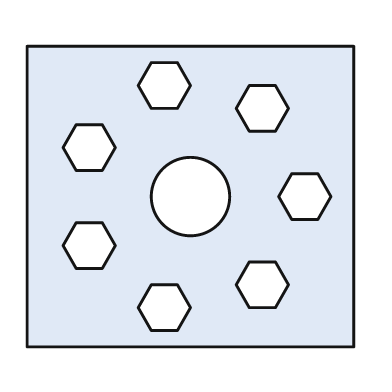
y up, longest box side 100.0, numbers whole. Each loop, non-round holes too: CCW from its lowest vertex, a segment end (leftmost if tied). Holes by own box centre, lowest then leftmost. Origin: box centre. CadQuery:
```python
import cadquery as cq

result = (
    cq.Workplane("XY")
    .moveTo(-50.0, -46.0)
    .lineTo(50.0, -46.0)
    .lineTo(50.0, 46.0)
    .lineTo(-50.0, 46.0)
    .close()
    .moveTo(-12.0, -41.0)
    .lineTo(-4.0, -41.0)
    .lineTo(0.0, -34.0)
    .lineTo(-4.0, -27.0)
    .lineTo(-12.0, -27.0)
    .lineTo(-16.0, -34.0)
    .close()
    .moveTo(18.0, -34.0)
    .lineTo(26.0, -34.0)
    .lineTo(30.0, -27.0)
    .lineTo(26.0, -20.0)
    .lineTo(18.0, -20.0)
    .lineTo(14.0, -27.0)
    .close()
    .moveTo(-35.0, -22.0)
    .lineTo(-27.0, -22.0)
    .lineTo(-23.0, -15.0)
    .lineTo(-27.0, -8.0)
    .lineTo(-35.0, -8.0)
    .lineTo(-39.0, -15.0)
    .close()
    .moveTo(0.0, 0.0)
    .circle(12.0)
    .moveTo(31.0, -7.0)
    .lineTo(39.0, -7.0)
    .lineTo(43.0, 0.0)
    .lineTo(39.0, 7.0)
    .lineTo(31.0, 7.0)
    .lineTo(27.0, 0.0)
    .close()
    .moveTo(-35.0, 8.0)
    .lineTo(-27.0, 8.0)
    .lineTo(-23.0, 15.0)
    .lineTo(-27.0, 22.0)
    .lineTo(-35.0, 22.0)
    .lineTo(-39.0, 15.0)
    .close()
    .moveTo(18.0, 20.0)
    .lineTo(26.0, 20.0)
    .lineTo(30.0, 27.0)
    .lineTo(26.0, 34.0)
    .lineTo(18.0, 34.0)
    .lineTo(14.0, 27.0)
    .close()
    .moveTo(-12.0, 27.0)
    .lineTo(-4.0, 27.0)
    .lineTo(0.0, 34.0)
    .lineTo(-4.0, 41.0)
    .lineTo(-12.0, 41.0)
    .lineTo(-16.0, 34.0)
    .close()
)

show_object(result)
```